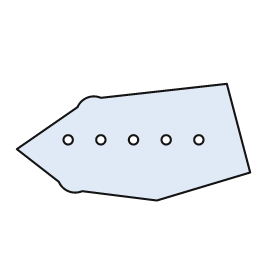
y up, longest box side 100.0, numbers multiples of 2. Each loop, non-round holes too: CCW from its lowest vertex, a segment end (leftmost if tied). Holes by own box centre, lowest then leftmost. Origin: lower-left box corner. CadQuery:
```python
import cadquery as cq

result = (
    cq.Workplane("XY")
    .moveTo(60.0, 0.0)
    .lineTo(100.0, 12.0)
    .lineTo(90.0, 50.0)
    .lineTo(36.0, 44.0)
    .threePointArc((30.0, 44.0), (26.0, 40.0))
    .lineTo(0.0, 22.0)
    .lineTo(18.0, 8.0)
    .threePointArc((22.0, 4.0), (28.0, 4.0))
    .close()
    .moveTo(22.0, 26.0)
    .circle(2.0)
    .moveTo(36.0, 26.0)
    .circle(2.0)
    .moveTo(50.0, 26.0)
    .circle(2.0)
    .moveTo(64.0, 26.0)
    .circle(2.0)
    .moveTo(78.0, 26.0)
    .circle(2.0)
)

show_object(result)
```